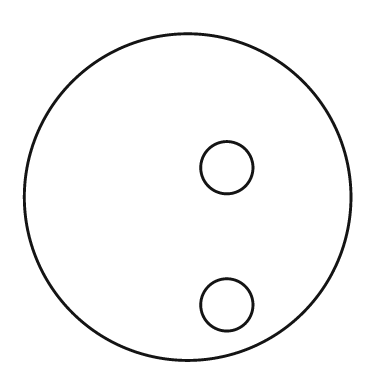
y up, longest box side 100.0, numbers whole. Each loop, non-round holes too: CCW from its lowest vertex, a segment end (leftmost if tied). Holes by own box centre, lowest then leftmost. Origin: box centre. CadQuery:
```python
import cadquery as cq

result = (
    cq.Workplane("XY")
    .moveTo(0.0, 0.0)
    .circle(50.0)
    .moveTo(12.0, -33.0)
    .circle(8.0)
    .moveTo(12.0, 9.0)
    .circle(8.0)
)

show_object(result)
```